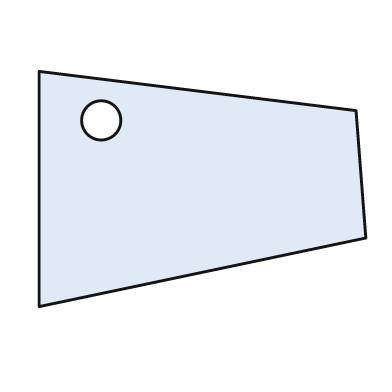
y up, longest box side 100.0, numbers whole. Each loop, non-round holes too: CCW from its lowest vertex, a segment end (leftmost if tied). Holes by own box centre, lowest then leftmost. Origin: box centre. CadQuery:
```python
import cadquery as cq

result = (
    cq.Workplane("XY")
    .moveTo(-50.0, -36.0)
    .lineTo(50.0, -15.0)
    .lineTo(47.0, 24.0)
    .lineTo(-50.0, 36.0)
    .close()
    .moveTo(-31.0, 21.0)
    .circle(6.0)
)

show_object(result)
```